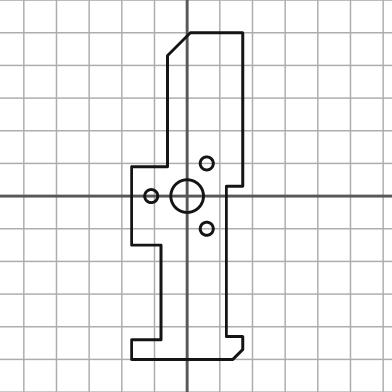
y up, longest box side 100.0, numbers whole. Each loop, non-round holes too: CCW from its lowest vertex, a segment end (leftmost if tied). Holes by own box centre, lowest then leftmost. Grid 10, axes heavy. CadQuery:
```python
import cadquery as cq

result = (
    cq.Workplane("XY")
    .moveTo(-17.0, -50.0)
    .lineTo(14.0, -50.0)
    .lineTo(17.0, -47.0)
    .lineTo(17.0, -43.0)
    .lineTo(12.0, -43.0)
    .lineTo(12.0, 3.0)
    .lineTo(17.0, 3.0)
    .lineTo(17.0, 50.0)
    .lineTo(1.0, 50.0)
    .lineTo(-6.0, 43.0)
    .lineTo(-6.0, 9.0)
    .lineTo(-17.0, 9.0)
    .lineTo(-17.0, -15.0)
    .lineTo(-8.0, -15.0)
    .lineTo(-8.0, -44.0)
    .lineTo(-17.0, -44.0)
    .close()
    .moveTo(6.0, -10.0)
    .circle(2.0)
    .moveTo(-11.0, 0.0)
    .circle(2.0)
    .moveTo(0.0, 0.0)
    .circle(5.0)
    .moveTo(6.0, 10.0)
    .circle(2.0)
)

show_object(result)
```